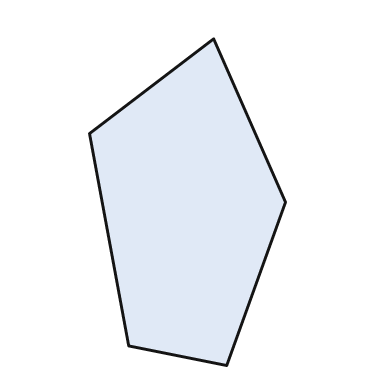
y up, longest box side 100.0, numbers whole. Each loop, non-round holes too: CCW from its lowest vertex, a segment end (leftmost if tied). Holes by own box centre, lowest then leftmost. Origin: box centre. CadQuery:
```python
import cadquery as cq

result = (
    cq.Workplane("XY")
    .moveTo(12.0, -50.0)
    .lineTo(30.0, 0.0)
    .lineTo(8.0, 50.0)
    .lineTo(-30.0, 21.0)
    .lineTo(-18.0, -44.0)
    .close()
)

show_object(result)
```